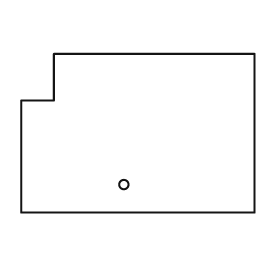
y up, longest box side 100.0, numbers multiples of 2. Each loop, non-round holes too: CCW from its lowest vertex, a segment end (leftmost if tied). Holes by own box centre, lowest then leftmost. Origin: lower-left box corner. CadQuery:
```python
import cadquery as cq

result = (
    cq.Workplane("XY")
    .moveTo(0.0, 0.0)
    .lineTo(100.0, 0.0)
    .lineTo(100.0, 68.0)
    .lineTo(14.0, 68.0)
    .lineTo(14.0, 48.0)
    .lineTo(0.0, 48.0)
    .close()
    .moveTo(44.0, 12.0)
    .circle(2.0)
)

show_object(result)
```